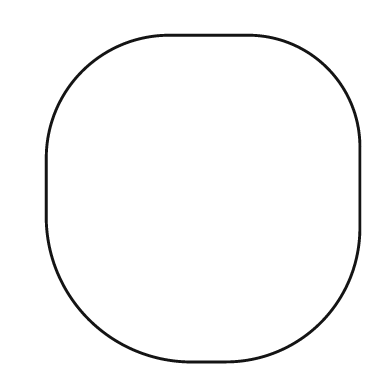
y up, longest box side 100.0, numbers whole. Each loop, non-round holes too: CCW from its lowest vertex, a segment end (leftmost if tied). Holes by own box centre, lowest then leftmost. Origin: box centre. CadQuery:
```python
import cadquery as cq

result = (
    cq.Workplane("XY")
    .moveTo(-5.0, -50.0)
    .lineTo(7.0, -50.0)
    .threePointArc((36.0, -38.0), (48.0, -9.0))
    .lineTo(48.0, 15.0)
    .threePointArc((38.0, 40.0), (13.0, 50.0))
    .lineTo(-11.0, 50.0)
    .threePointArc((-37.0, 39.0), (-48.0, 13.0))
    .lineTo(-48.0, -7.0)
    .threePointArc((-35.0, -37.0), (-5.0, -50.0))
    .close()
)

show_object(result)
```